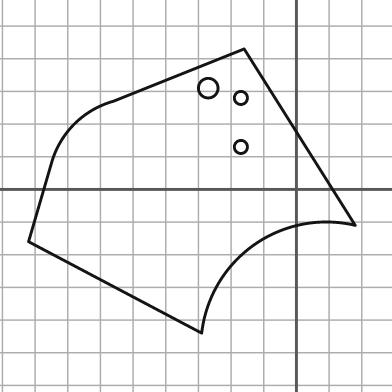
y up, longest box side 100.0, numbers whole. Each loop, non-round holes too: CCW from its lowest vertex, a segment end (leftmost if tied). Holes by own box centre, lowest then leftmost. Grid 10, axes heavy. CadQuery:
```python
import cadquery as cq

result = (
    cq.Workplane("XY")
    .moveTo(-29.0, -44.0)
    .threePointArc((-13.0, -17.0), (18.0, -11.0))
    .lineTo(-16.0, 43.0)
    .lineTo(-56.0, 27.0)
    .threePointArc((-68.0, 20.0), (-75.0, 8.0))
    .lineTo(-82.0, -16.0)
    .close()
    .moveTo(-17.0, 13.0)
    .circle(2.0)
    .moveTo(-17.0, 28.0)
    .circle(2.0)
    .moveTo(-27.0, 31.0)
    .circle(3.0)
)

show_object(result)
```